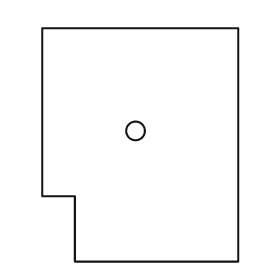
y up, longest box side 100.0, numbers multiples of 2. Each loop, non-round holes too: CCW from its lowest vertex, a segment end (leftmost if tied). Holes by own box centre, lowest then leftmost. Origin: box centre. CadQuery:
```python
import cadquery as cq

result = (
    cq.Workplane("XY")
    .moveTo(-28.0, -50.0)
    .lineTo(42.0, -50.0)
    .lineTo(42.0, 50.0)
    .lineTo(-42.0, 50.0)
    .lineTo(-42.0, -22.0)
    .lineTo(-28.0, -22.0)
    .close()
    .moveTo(-2.0, 6.0)
    .circle(4.0)
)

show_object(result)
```